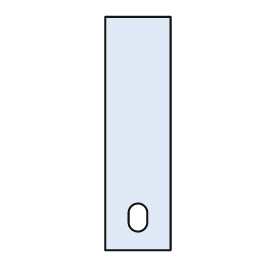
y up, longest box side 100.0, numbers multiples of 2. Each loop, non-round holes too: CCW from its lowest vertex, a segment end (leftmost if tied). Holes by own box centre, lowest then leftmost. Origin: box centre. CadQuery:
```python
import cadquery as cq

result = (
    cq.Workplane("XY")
    .moveTo(-14.0, -50.0)
    .lineTo(14.0, -50.0)
    .lineTo(14.0, 50.0)
    .lineTo(-14.0, 50.0)
    .close()
    .moveTo(-4.0, -38.0)
    .threePointArc((0.0, -42.0), (4.0, -38.0))
    .lineTo(4.0, -34.0)
    .threePointArc((0.0, -30.0), (-4.0, -34.0))
    .close()
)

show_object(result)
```